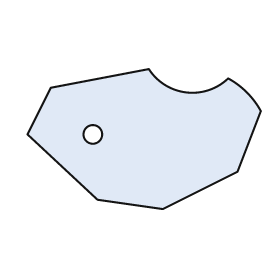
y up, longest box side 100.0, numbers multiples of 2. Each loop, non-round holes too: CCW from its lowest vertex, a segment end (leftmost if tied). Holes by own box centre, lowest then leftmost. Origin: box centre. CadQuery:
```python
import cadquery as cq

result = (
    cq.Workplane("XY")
    .moveTo(8.0, -30.0)
    .lineTo(40.0, -14.0)
    .lineTo(50.0, 12.0)
    .threePointArc((44.0, 20.0), (36.0, 26.0))
    .threePointArc((18.0, 20.0), (2.0, 30.0))
    .lineTo(-40.0, 22.0)
    .lineTo(-50.0, 2.0)
    .lineTo(-20.0, -26.0)
    .close()
    .moveTo(-22.0, 2.0)
    .circle(4.0)
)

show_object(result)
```